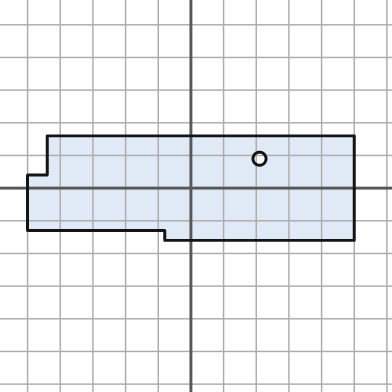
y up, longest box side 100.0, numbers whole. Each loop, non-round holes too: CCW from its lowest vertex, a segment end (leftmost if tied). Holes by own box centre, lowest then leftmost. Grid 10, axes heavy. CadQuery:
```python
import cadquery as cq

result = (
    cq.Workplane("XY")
    .moveTo(-8.0, -16.0)
    .lineTo(50.0, -16.0)
    .lineTo(50.0, 16.0)
    .lineTo(-44.0, 16.0)
    .lineTo(-44.0, 4.0)
    .lineTo(-50.0, 4.0)
    .lineTo(-50.0, -13.0)
    .lineTo(-8.0, -13.0)
    .close()
    .moveTo(21.0, 9.0)
    .circle(2.0)
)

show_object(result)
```